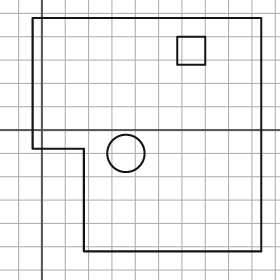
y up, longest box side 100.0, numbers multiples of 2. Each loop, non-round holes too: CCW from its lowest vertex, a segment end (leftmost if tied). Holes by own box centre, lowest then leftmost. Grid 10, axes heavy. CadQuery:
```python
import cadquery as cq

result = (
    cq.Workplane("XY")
    .moveTo(18.0, -52.0)
    .lineTo(94.0, -52.0)
    .lineTo(94.0, 48.0)
    .lineTo(-4.0, 48.0)
    .lineTo(-4.0, -8.0)
    .lineTo(18.0, -8.0)
    .close()
    .moveTo(36.0, -10.0)
    .circle(8.0)
    .moveTo(58.0, 28.0)
    .lineTo(70.0, 28.0)
    .lineTo(70.0, 40.0)
    .lineTo(58.0, 40.0)
    .close()
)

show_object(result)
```